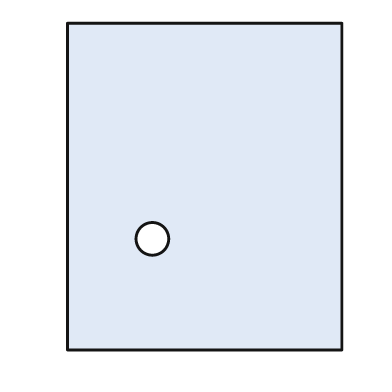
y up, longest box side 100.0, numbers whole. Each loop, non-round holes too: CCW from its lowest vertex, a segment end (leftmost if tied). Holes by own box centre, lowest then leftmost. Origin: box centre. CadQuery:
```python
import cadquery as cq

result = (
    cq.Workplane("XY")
    .moveTo(-42.0, -50.0)
    .lineTo(42.0, -50.0)
    .lineTo(42.0, 50.0)
    .lineTo(-42.0, 50.0)
    .close()
    .moveTo(-16.0, -16.0)
    .circle(5.0)
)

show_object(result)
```